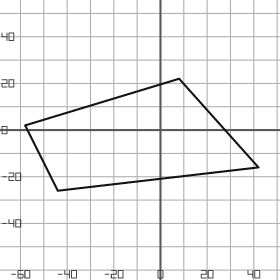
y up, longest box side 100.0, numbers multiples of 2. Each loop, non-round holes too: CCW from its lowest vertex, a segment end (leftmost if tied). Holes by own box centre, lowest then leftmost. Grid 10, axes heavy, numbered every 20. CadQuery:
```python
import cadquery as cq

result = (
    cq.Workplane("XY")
    .moveTo(-44.0, -26.0)
    .lineTo(42.0, -16.0)
    .lineTo(8.0, 22.0)
    .lineTo(-58.0, 2.0)
    .close()
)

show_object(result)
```